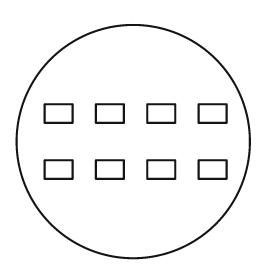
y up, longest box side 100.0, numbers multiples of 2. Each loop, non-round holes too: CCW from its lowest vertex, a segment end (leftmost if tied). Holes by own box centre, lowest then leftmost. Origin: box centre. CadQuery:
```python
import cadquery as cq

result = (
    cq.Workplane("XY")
    .moveTo(0.0, 0.0)
    .circle(50.0)
    .moveTo(-38.0, -16.0)
    .lineTo(-26.0, -16.0)
    .lineTo(-26.0, -8.0)
    .lineTo(-38.0, -8.0)
    .close()
    .moveTo(-16.0, -16.0)
    .lineTo(-4.0, -16.0)
    .lineTo(-4.0, -8.0)
    .lineTo(-16.0, -8.0)
    .close()
    .moveTo(6.0, -16.0)
    .lineTo(18.0, -16.0)
    .lineTo(18.0, -8.0)
    .lineTo(6.0, -8.0)
    .close()
    .moveTo(28.0, -16.0)
    .lineTo(40.0, -16.0)
    .lineTo(40.0, -8.0)
    .lineTo(28.0, -8.0)
    .close()
    .moveTo(-38.0, 8.0)
    .lineTo(-26.0, 8.0)
    .lineTo(-26.0, 16.0)
    .lineTo(-38.0, 16.0)
    .close()
    .moveTo(-16.0, 8.0)
    .lineTo(-4.0, 8.0)
    .lineTo(-4.0, 16.0)
    .lineTo(-16.0, 16.0)
    .close()
    .moveTo(6.0, 8.0)
    .lineTo(18.0, 8.0)
    .lineTo(18.0, 16.0)
    .lineTo(6.0, 16.0)
    .close()
    .moveTo(28.0, 8.0)
    .lineTo(40.0, 8.0)
    .lineTo(40.0, 16.0)
    .lineTo(28.0, 16.0)
    .close()
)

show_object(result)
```